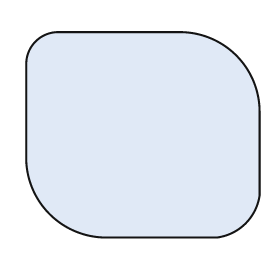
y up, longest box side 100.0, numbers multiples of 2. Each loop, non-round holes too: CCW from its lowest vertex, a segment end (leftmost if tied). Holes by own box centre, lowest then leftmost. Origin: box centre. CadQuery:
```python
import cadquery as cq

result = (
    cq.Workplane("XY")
    .moveTo(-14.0, -44.0)
    .lineTo(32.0, -44.0)
    .threePointArc((44.0, -38.0), (50.0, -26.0))
    .lineTo(50.0, 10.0)
    .threePointArc((40.0, 34.0), (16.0, 44.0))
    .lineTo(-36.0, 44.0)
    .threePointArc((-46.0, 40.0), (-50.0, 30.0))
    .lineTo(-50.0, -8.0)
    .threePointArc((-40.0, -34.0), (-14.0, -44.0))
    .close()
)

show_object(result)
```